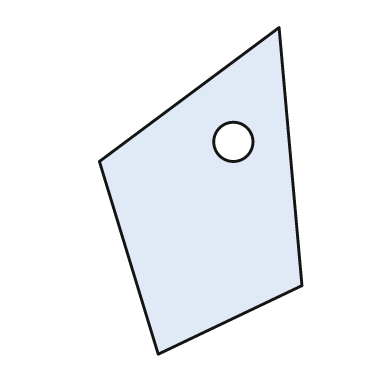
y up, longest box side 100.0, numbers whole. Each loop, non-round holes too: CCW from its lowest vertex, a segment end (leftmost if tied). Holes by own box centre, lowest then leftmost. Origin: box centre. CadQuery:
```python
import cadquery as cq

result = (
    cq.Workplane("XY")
    .moveTo(-13.0, -50.0)
    .lineTo(31.0, -29.0)
    .lineTo(24.0, 50.0)
    .lineTo(-31.0, 9.0)
    .close()
    .moveTo(10.0, 15.0)
    .circle(6.0)
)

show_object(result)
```